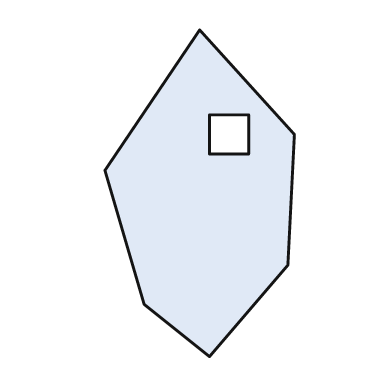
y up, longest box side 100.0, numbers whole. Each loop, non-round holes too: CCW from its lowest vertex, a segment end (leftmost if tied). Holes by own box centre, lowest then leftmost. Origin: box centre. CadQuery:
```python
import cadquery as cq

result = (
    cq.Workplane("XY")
    .moveTo(3.0, -50.0)
    .lineTo(27.0, -22.0)
    .lineTo(29.0, 18.0)
    .lineTo(0.0, 50.0)
    .lineTo(-29.0, 7.0)
    .lineTo(-17.0, -34.0)
    .close()
    .moveTo(3.0, 12.0)
    .lineTo(15.0, 12.0)
    .lineTo(15.0, 24.0)
    .lineTo(3.0, 24.0)
    .close()
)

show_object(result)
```